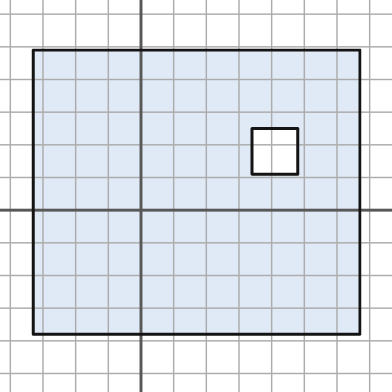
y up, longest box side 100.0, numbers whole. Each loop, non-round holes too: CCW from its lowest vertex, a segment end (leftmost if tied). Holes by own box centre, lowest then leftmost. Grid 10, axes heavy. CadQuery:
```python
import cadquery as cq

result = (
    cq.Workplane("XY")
    .moveTo(-33.0, -38.0)
    .lineTo(67.0, -38.0)
    .lineTo(67.0, 49.0)
    .lineTo(-33.0, 49.0)
    .close()
    .moveTo(34.0, 11.0)
    .lineTo(48.0, 11.0)
    .lineTo(48.0, 25.0)
    .lineTo(34.0, 25.0)
    .close()
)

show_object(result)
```